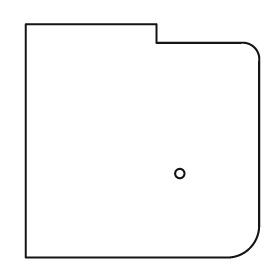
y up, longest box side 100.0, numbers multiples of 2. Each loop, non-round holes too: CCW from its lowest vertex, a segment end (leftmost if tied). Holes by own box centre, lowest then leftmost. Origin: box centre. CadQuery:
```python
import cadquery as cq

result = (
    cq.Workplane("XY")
    .moveTo(-50.0, -50.0)
    .lineTo(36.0, -50.0)
    .threePointArc((46.0, -46.0), (50.0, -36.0))
    .lineTo(50.0, 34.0)
    .threePointArc((48.0, 40.0), (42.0, 42.0))
    .lineTo(6.0, 42.0)
    .lineTo(6.0, 50.0)
    .lineTo(-50.0, 50.0)
    .close()
    .moveTo(16.0, -14.0)
    .circle(2.0)
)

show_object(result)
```